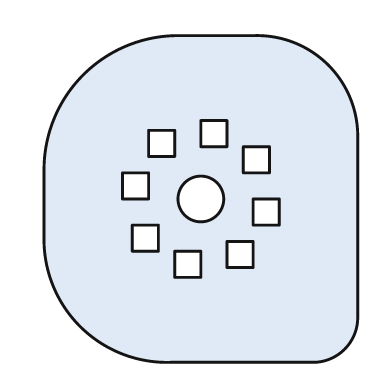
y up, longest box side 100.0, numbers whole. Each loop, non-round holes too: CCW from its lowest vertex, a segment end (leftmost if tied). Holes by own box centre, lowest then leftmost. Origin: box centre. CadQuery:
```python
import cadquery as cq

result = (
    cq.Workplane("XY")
    .moveTo(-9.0, -50.0)
    .lineTo(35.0, -50.0)
    .threePointArc((44.0, -46.0), (48.0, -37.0))
    .lineTo(48.0, 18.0)
    .threePointArc((39.0, 41.0), (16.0, 50.0))
    .lineTo(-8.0, 50.0)
    .threePointArc((-36.0, 38.0), (-48.0, 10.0))
    .lineTo(-48.0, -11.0)
    .threePointArc((-37.0, -39.0), (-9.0, -50.0))
    .close()
    .moveTo(-8.0, -24.0)
    .lineTo(0.0, -24.0)
    .lineTo(0.0, -16.0)
    .lineTo(-8.0, -16.0)
    .close()
    .moveTo(8.0, -21.0)
    .lineTo(16.0, -21.0)
    .lineTo(16.0, -13.0)
    .lineTo(8.0, -13.0)
    .close()
    .moveTo(-21.0, -16.0)
    .lineTo(-13.0, -16.0)
    .lineTo(-13.0, -8.0)
    .lineTo(-21.0, -8.0)
    .close()
    .moveTo(16.0, -8.0)
    .lineTo(24.0, -8.0)
    .lineTo(24.0, 0.0)
    .lineTo(16.0, 0.0)
    .close()
    .moveTo(0.0, 0.0)
    .circle(7.0)
    .moveTo(-24.0, 0.0)
    .lineTo(-16.0, 0.0)
    .lineTo(-16.0, 8.0)
    .lineTo(-24.0, 8.0)
    .close()
    .moveTo(13.0, 8.0)
    .lineTo(21.0, 8.0)
    .lineTo(21.0, 16.0)
    .lineTo(13.0, 16.0)
    .close()
    .moveTo(-16.0, 13.0)
    .lineTo(-8.0, 13.0)
    .lineTo(-8.0, 21.0)
    .lineTo(-16.0, 21.0)
    .close()
    .moveTo(0.0, 16.0)
    .lineTo(8.0, 16.0)
    .lineTo(8.0, 24.0)
    .lineTo(0.0, 24.0)
    .close()
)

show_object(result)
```